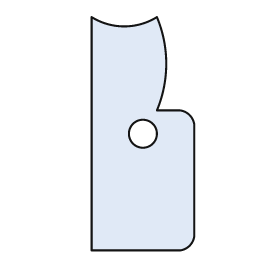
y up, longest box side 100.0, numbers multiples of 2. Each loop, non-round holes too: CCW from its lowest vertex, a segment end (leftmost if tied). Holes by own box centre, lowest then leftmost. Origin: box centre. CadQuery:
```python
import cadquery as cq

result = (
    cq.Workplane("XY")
    .moveTo(-22.0, -50.0)
    .lineTo(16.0, -50.0)
    .threePointArc((20.0, -48.0), (22.0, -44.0))
    .lineTo(22.0, 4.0)
    .threePointArc((20.0, 8.0), (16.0, 10.0))
    .lineTo(6.0, 10.0)
    .threePointArc((10.0, 30.0), (6.0, 50.0))
    .threePointArc((-8.0, 46.0), (-22.0, 50.0))
    .close()
    .moveTo(0.0, 0.0)
    .circle(6.0)
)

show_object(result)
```